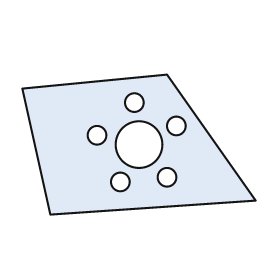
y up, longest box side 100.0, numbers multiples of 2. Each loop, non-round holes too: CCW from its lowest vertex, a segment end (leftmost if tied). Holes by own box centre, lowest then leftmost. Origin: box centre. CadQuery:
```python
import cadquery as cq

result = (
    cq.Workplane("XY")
    .moveTo(-38.0, -30.0)
    .lineTo(50.0, -24.0)
    .lineTo(12.0, 30.0)
    .lineTo(-50.0, 24.0)
    .close()
    .moveTo(-8.0, -16.0)
    .circle(4.0)
    .moveTo(12.0, -14.0)
    .circle(4.0)
    .moveTo(0.0, 0.0)
    .circle(10.0)
    .moveTo(-18.0, 4.0)
    .circle(4.0)
    .moveTo(16.0, 8.0)
    .circle(4.0)
    .moveTo(-2.0, 18.0)
    .circle(4.0)
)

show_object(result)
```